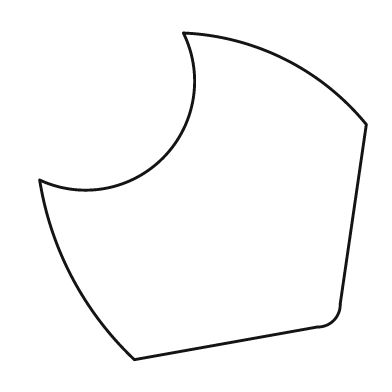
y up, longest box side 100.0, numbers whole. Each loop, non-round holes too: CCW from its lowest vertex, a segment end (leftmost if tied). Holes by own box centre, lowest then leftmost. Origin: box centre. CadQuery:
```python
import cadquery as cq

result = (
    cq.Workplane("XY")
    .moveTo(-21.0, -50.0)
    .lineTo(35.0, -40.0)
    .threePointArc((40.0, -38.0), (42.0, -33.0))
    .lineTo(50.0, 22.0)
    .threePointArc((25.0, 42.0), (-6.0, 50.0))
    .threePointArc((-12.0, 12.0), (-50.0, 5.0))
    .threePointArc((-40.0, -25.0), (-21.0, -50.0))
    .close()
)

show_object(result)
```